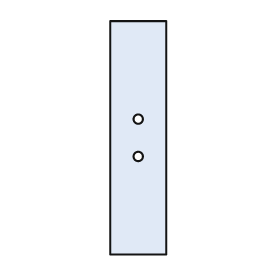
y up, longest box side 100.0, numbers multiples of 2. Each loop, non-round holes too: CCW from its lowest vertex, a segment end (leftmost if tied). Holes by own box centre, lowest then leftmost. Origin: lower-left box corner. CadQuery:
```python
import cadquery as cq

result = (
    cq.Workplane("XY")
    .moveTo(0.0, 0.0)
    .lineTo(24.0, 0.0)
    .lineTo(24.0, 100.0)
    .lineTo(0.0, 100.0)
    .close()
    .moveTo(12.0, 42.0)
    .circle(2.0)
    .moveTo(12.0, 58.0)
    .circle(2.0)
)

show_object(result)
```